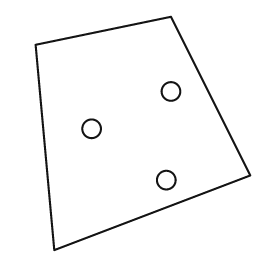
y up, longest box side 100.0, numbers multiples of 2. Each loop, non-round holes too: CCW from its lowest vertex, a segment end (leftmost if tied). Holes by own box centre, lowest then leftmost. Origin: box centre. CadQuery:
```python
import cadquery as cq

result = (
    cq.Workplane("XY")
    .moveTo(-38.0, -50.0)
    .lineTo(46.0, -18.0)
    .lineTo(12.0, 50.0)
    .lineTo(-46.0, 38.0)
    .close()
    .moveTo(10.0, -20.0)
    .circle(4.0)
    .moveTo(-22.0, 2.0)
    .circle(4.0)
    .moveTo(12.0, 18.0)
    .circle(4.0)
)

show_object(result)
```